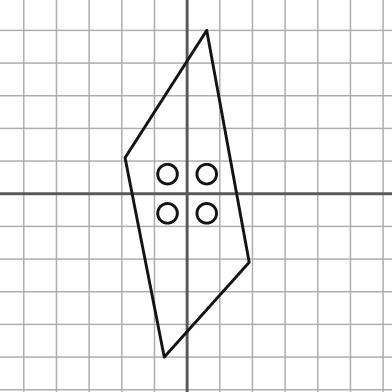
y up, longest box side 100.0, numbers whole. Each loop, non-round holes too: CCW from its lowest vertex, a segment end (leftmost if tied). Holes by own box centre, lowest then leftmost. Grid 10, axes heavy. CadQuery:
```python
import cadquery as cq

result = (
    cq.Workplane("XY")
    .moveTo(-7.0, -50.0)
    .lineTo(19.0, -21.0)
    .lineTo(6.0, 50.0)
    .lineTo(-19.0, 11.0)
    .close()
    .moveTo(-6.0, -6.0)
    .circle(3.0)
    .moveTo(6.0, -6.0)
    .circle(3.0)
    .moveTo(-6.0, 6.0)
    .circle(3.0)
    .moveTo(6.0, 6.0)
    .circle(3.0)
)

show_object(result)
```